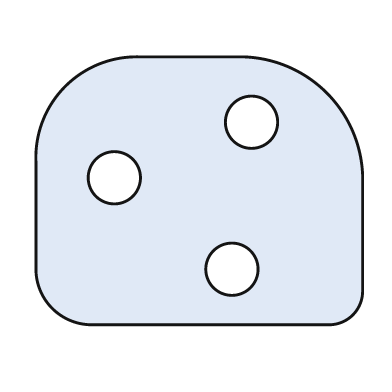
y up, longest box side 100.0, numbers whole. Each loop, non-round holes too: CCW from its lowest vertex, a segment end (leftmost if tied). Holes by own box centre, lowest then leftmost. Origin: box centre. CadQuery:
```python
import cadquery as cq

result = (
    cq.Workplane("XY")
    .moveTo(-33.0, -41.0)
    .lineTo(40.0, -41.0)
    .threePointArc((47.0, -38.0), (50.0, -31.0))
    .lineTo(50.0, 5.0)
    .threePointArc((39.0, 30.0), (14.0, 41.0))
    .lineTo(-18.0, 41.0)
    .threePointArc((-41.0, 32.0), (-50.0, 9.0))
    .lineTo(-50.0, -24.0)
    .threePointArc((-45.0, -36.0), (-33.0, -41.0))
    .close()
    .moveTo(10.0, -24.0)
    .circle(8.0)
    .moveTo(-26.0, 4.0)
    .circle(8.0)
    .moveTo(16.0, 21.0)
    .circle(8.0)
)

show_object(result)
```